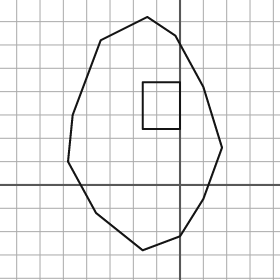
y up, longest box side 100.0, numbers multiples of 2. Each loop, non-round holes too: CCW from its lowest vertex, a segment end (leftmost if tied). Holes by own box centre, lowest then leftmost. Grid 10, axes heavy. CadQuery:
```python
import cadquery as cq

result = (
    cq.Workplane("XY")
    .moveTo(-16.0, -28.0)
    .lineTo(0.0, -22.0)
    .lineTo(10.0, -6.0)
    .lineTo(18.0, 16.0)
    .lineTo(10.0, 42.0)
    .lineTo(-2.0, 64.0)
    .lineTo(-14.0, 72.0)
    .lineTo(-34.0, 62.0)
    .lineTo(-46.0, 30.0)
    .lineTo(-48.0, 10.0)
    .lineTo(-36.0, -12.0)
    .close()
    .moveTo(-16.0, 24.0)
    .lineTo(0.0, 24.0)
    .lineTo(0.0, 44.0)
    .lineTo(-16.0, 44.0)
    .close()
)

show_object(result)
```